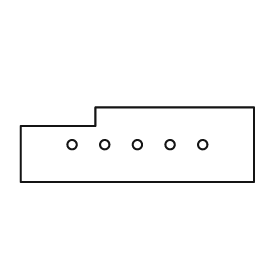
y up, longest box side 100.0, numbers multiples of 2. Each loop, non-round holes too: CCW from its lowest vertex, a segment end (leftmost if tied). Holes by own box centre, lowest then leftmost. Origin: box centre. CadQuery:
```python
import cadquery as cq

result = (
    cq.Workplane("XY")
    .moveTo(-50.0, -16.0)
    .lineTo(50.0, -16.0)
    .lineTo(50.0, 16.0)
    .lineTo(-18.0, 16.0)
    .lineTo(-18.0, 8.0)
    .lineTo(-50.0, 8.0)
    .close()
    .moveTo(-28.0, 0.0)
    .circle(2.0)
    .moveTo(-14.0, 0.0)
    .circle(2.0)
    .moveTo(0.0, 0.0)
    .circle(2.0)
    .moveTo(14.0, 0.0)
    .circle(2.0)
    .moveTo(28.0, 0.0)
    .circle(2.0)
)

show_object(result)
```